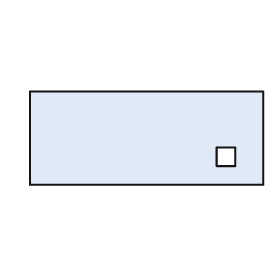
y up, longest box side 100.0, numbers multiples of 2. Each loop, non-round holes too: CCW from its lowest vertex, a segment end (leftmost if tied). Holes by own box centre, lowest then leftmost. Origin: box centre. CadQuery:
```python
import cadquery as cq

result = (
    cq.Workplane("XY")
    .moveTo(-50.0, -20.0)
    .lineTo(50.0, -20.0)
    .lineTo(50.0, 20.0)
    .lineTo(-50.0, 20.0)
    .close()
    .moveTo(30.0, -12.0)
    .lineTo(38.0, -12.0)
    .lineTo(38.0, -4.0)
    .lineTo(30.0, -4.0)
    .close()
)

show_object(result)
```